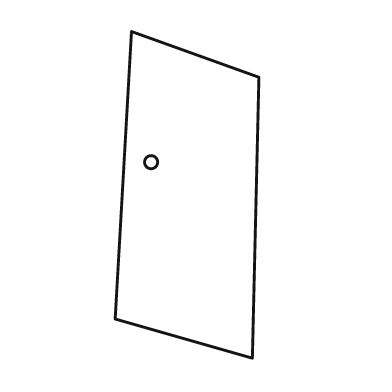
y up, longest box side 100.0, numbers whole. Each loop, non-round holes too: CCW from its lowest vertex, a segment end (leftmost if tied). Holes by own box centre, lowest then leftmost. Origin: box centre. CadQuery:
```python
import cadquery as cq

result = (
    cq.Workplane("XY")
    .moveTo(20.0, -50.0)
    .lineTo(22.0, 36.0)
    .lineTo(-17.0, 50.0)
    .lineTo(-22.0, -38.0)
    .close()
    .moveTo(-11.0, 10.0)
    .circle(2.0)
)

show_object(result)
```